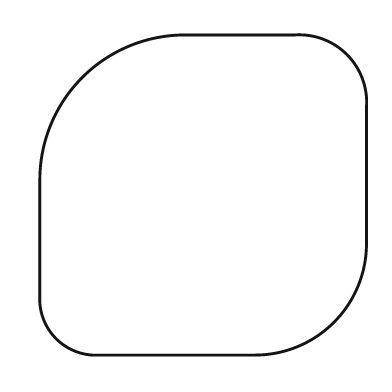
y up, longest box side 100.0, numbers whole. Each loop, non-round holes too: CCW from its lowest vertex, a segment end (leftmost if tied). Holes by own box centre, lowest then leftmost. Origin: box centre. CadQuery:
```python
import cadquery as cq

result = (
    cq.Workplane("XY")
    .moveTo(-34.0, -49.0)
    .lineTo(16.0, -49.0)
    .threePointArc((40.0, -39.0), (50.0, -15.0))
    .lineTo(50.0, 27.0)
    .threePointArc((44.0, 43.0), (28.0, 49.0))
    .lineTo(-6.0, 49.0)
    .threePointArc((-37.0, 36.0), (-50.0, 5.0))
    .lineTo(-50.0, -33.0)
    .threePointArc((-45.0, -44.0), (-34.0, -49.0))
    .close()
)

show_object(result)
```